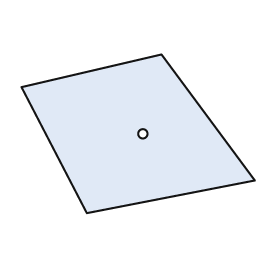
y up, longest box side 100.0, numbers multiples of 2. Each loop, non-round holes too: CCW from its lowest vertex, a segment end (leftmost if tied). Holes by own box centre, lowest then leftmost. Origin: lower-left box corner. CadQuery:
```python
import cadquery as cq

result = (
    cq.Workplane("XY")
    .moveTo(28.0, 0.0)
    .lineTo(100.0, 14.0)
    .lineTo(60.0, 68.0)
    .lineTo(0.0, 54.0)
    .close()
    .moveTo(52.0, 34.0)
    .circle(2.0)
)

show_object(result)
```